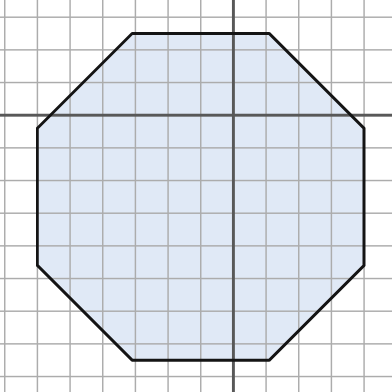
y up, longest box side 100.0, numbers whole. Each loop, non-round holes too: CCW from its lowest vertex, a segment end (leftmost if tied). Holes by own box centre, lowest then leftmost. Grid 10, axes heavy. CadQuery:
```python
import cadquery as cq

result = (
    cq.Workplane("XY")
    .moveTo(-31.0, -75.0)
    .lineTo(11.0, -75.0)
    .lineTo(40.0, -46.0)
    .lineTo(40.0, -4.0)
    .lineTo(11.0, 25.0)
    .lineTo(-31.0, 25.0)
    .lineTo(-60.0, -4.0)
    .lineTo(-60.0, -46.0)
    .close()
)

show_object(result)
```